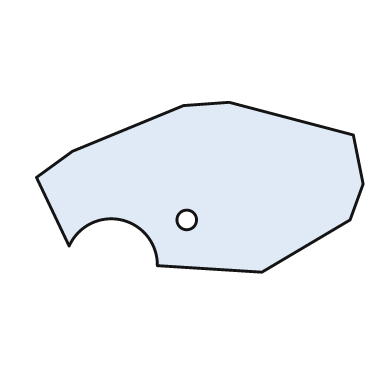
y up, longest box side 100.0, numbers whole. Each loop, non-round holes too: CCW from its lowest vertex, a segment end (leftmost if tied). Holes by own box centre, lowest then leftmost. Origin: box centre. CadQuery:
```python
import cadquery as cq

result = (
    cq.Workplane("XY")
    .moveTo(19.0, -26.0)
    .lineTo(46.0, -10.0)
    .lineTo(50.0, 1.0)
    .lineTo(47.0, 16.0)
    .lineTo(9.0, 26.0)
    .lineTo(-5.0, 25.0)
    .lineTo(-39.0, 11.0)
    .lineTo(-50.0, 3.0)
    .lineTo(-40.0, -18.0)
    .threePointArc((-24.0, -10.0), (-13.0, -24.0))
    .close()
    .moveTo(-4.0, -10.0)
    .circle(3.0)
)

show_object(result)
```